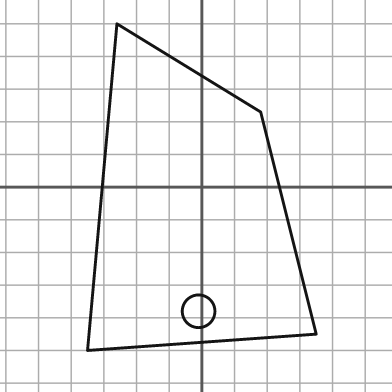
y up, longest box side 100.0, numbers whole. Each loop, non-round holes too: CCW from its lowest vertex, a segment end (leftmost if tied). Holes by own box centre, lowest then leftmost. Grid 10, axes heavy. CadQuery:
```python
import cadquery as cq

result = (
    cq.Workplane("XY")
    .moveTo(-35.0, -50.0)
    .lineTo(35.0, -45.0)
    .lineTo(18.0, 23.0)
    .lineTo(-26.0, 50.0)
    .close()
    .moveTo(-1.0, -38.0)
    .circle(5.0)
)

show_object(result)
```